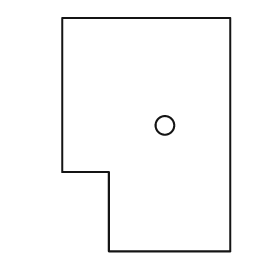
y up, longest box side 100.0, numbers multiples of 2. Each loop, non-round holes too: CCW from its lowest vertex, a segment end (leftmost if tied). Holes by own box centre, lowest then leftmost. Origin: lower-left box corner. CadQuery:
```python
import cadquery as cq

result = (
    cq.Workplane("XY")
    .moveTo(20.0, 0.0)
    .lineTo(72.0, 0.0)
    .lineTo(72.0, 100.0)
    .lineTo(0.0, 100.0)
    .lineTo(0.0, 34.0)
    .lineTo(20.0, 34.0)
    .close()
    .moveTo(44.0, 54.0)
    .circle(4.0)
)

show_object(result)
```